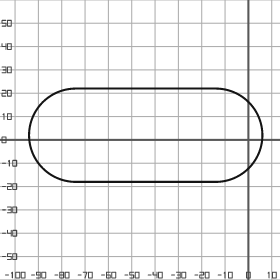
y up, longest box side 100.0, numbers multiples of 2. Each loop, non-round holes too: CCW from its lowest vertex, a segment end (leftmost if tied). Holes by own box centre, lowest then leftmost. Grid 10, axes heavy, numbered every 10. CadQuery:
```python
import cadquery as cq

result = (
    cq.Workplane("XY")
    .moveTo(-74.0, -18.0)
    .lineTo(-14.0, -18.0)
    .threePointArc((6.0, 2.0), (-14.0, 22.0))
    .lineTo(-74.0, 22.0)
    .threePointArc((-94.0, 2.0), (-74.0, -18.0))
    .close()
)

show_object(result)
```